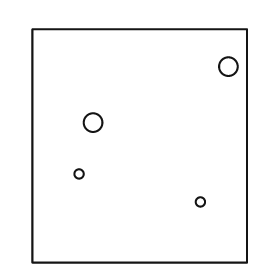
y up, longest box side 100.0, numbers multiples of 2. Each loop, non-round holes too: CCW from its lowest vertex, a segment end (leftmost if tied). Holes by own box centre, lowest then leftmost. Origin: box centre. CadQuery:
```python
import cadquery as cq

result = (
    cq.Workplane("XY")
    .moveTo(-46.0, -50.0)
    .lineTo(46.0, -50.0)
    .lineTo(46.0, 50.0)
    .lineTo(-46.0, 50.0)
    .close()
    .moveTo(26.0, -24.0)
    .circle(2.0)
    .moveTo(-26.0, -12.0)
    .circle(2.0)
    .moveTo(-20.0, 10.0)
    .circle(4.0)
    .moveTo(38.0, 34.0)
    .circle(4.0)
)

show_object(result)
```